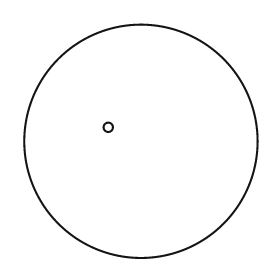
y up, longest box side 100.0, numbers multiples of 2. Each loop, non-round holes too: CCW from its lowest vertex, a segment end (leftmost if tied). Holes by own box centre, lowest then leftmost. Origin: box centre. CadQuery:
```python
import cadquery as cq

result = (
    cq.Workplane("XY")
    .moveTo(0.0, 0.0)
    .circle(50.0)
    .moveTo(-14.0, 6.0)
    .circle(2.0)
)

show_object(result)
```